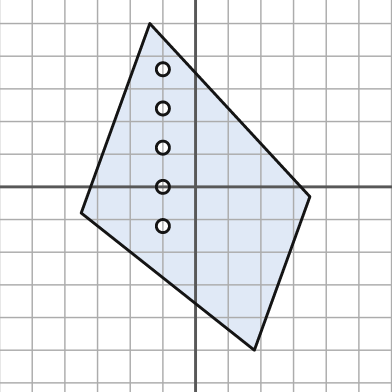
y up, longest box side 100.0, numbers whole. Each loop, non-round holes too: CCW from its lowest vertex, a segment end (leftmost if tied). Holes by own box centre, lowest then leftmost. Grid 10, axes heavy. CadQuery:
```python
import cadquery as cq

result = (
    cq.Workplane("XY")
    .moveTo(18.0, -50.0)
    .lineTo(35.0, -3.0)
    .lineTo(-14.0, 50.0)
    .lineTo(-35.0, -8.0)
    .close()
    .moveTo(-10.0, -12.0)
    .circle(2.0)
    .moveTo(-10.0, 0.0)
    .circle(2.0)
    .moveTo(-10.0, 12.0)
    .circle(2.0)
    .moveTo(-10.0, 24.0)
    .circle(2.0)
    .moveTo(-10.0, 36.0)
    .circle(2.0)
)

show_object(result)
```